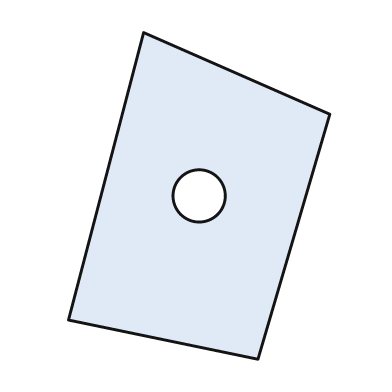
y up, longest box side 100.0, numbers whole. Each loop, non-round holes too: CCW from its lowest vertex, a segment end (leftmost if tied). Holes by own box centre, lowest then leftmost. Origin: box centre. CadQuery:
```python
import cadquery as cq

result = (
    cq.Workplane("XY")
    .moveTo(18.0, -50.0)
    .lineTo(40.0, 25.0)
    .lineTo(-17.0, 50.0)
    .lineTo(-40.0, -38.0)
    .close()
    .moveTo(0.0, 0.0)
    .circle(8.0)
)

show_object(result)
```